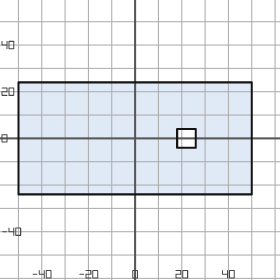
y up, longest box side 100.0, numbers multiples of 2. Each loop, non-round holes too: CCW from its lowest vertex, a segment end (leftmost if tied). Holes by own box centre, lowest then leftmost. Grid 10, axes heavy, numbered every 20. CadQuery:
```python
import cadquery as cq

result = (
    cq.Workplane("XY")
    .moveTo(-50.0, -24.0)
    .lineTo(50.0, -24.0)
    .lineTo(50.0, 24.0)
    .lineTo(-50.0, 24.0)
    .close()
    .moveTo(18.0, -4.0)
    .lineTo(26.0, -4.0)
    .lineTo(26.0, 4.0)
    .lineTo(18.0, 4.0)
    .close()
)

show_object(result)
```